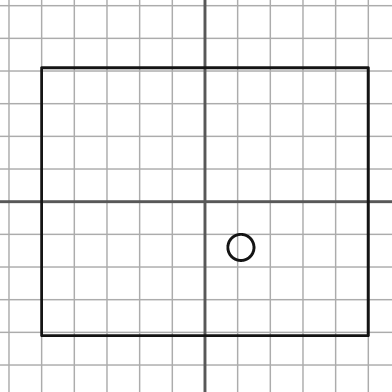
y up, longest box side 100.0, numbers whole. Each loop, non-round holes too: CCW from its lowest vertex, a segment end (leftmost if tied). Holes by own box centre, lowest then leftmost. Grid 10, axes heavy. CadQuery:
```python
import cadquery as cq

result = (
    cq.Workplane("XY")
    .moveTo(-50.0, -41.0)
    .lineTo(50.0, -41.0)
    .lineTo(50.0, 41.0)
    .lineTo(-50.0, 41.0)
    .close()
    .moveTo(11.0, -14.0)
    .circle(4.0)
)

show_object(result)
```